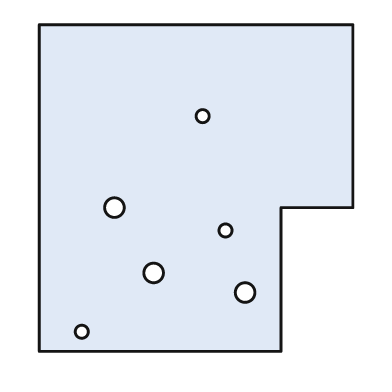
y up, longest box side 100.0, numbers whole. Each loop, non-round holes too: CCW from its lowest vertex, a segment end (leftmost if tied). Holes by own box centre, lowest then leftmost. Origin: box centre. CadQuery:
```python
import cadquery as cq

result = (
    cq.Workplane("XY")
    .moveTo(-48.0, -50.0)
    .lineTo(26.0, -50.0)
    .lineTo(26.0, -6.0)
    .lineTo(48.0, -6.0)
    .lineTo(48.0, 50.0)
    .lineTo(-48.0, 50.0)
    .close()
    .moveTo(-35.0, -44.0)
    .circle(2.0)
    .moveTo(15.0, -32.0)
    .circle(3.0)
    .moveTo(-13.0, -26.0)
    .circle(3.0)
    .moveTo(9.0, -13.0)
    .circle(2.0)
    .moveTo(-25.0, -6.0)
    .circle(3.0)
    .moveTo(2.0, 22.0)
    .circle(2.0)
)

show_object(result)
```